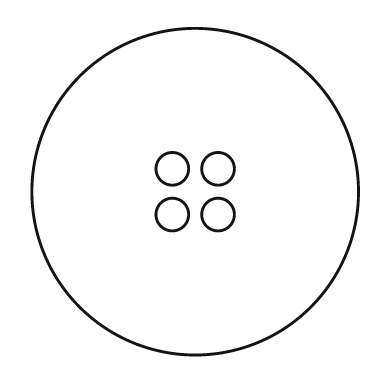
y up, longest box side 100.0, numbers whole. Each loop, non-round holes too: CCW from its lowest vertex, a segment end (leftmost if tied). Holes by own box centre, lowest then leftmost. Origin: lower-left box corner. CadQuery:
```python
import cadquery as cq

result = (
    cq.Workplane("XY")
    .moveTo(50.0, 50.0)
    .circle(50.0)
    .moveTo(43.0, 43.0)
    .circle(5.0)
    .moveTo(57.0, 43.0)
    .circle(5.0)
    .moveTo(43.0, 57.0)
    .circle(5.0)
    .moveTo(57.0, 57.0)
    .circle(5.0)
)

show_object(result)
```